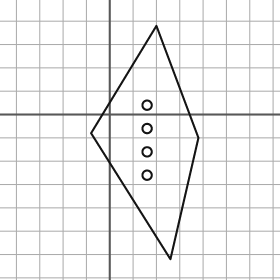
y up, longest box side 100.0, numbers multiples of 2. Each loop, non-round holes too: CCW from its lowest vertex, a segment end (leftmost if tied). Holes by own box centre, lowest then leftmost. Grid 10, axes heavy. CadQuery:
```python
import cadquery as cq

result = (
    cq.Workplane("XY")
    .moveTo(26.0, -62.0)
    .lineTo(38.0, -10.0)
    .lineTo(20.0, 38.0)
    .lineTo(-8.0, -8.0)
    .close()
    .moveTo(16.0, -26.0)
    .circle(2.0)
    .moveTo(16.0, -16.0)
    .circle(2.0)
    .moveTo(16.0, -6.0)
    .circle(2.0)
    .moveTo(16.0, 4.0)
    .circle(2.0)
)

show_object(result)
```